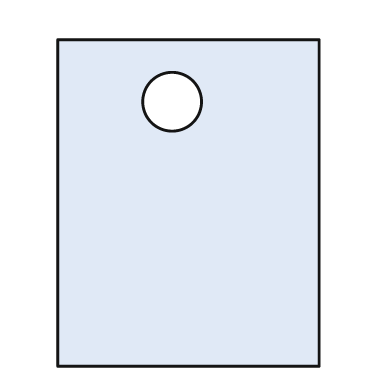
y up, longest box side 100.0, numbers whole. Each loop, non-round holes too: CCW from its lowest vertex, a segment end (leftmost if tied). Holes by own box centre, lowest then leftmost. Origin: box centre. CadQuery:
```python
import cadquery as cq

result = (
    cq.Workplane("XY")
    .moveTo(-40.0, -50.0)
    .lineTo(40.0, -50.0)
    .lineTo(40.0, 50.0)
    .lineTo(-40.0, 50.0)
    .close()
    .moveTo(-5.0, 31.0)
    .circle(9.0)
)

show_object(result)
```